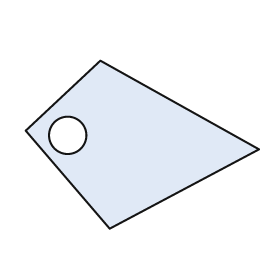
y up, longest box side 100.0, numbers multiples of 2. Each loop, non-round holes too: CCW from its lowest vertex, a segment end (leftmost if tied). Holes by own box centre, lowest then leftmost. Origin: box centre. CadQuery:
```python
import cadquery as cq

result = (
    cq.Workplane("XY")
    .moveTo(-14.0, -36.0)
    .lineTo(50.0, -2.0)
    .lineTo(-18.0, 36.0)
    .lineTo(-50.0, 6.0)
    .close()
    .moveTo(-32.0, 4.0)
    .circle(8.0)
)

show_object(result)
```